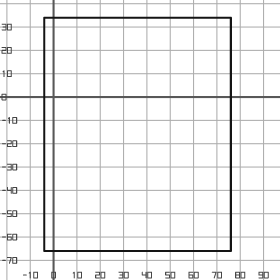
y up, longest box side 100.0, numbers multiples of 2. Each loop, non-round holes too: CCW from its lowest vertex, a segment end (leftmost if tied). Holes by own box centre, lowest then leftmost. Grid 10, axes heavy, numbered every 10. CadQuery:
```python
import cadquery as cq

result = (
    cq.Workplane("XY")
    .moveTo(-4.0, -66.0)
    .lineTo(76.0, -66.0)
    .lineTo(76.0, 34.0)
    .lineTo(-4.0, 34.0)
    .close()
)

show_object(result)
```